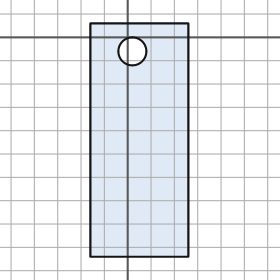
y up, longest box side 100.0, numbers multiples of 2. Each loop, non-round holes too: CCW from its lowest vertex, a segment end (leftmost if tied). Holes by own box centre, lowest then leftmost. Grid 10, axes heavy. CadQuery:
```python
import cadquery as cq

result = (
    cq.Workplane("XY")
    .moveTo(-16.0, -94.0)
    .lineTo(26.0, -94.0)
    .lineTo(26.0, 6.0)
    .lineTo(-16.0, 6.0)
    .close()
    .moveTo(2.0, -6.0)
    .circle(6.0)
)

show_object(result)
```